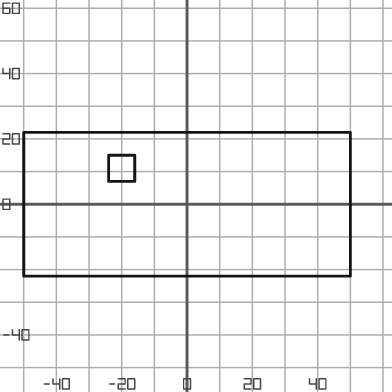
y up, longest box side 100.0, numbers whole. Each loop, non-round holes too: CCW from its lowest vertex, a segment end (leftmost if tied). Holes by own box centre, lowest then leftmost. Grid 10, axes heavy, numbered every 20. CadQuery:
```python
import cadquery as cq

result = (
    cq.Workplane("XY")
    .moveTo(-50.0, -22.0)
    .lineTo(50.0, -22.0)
    .lineTo(50.0, 22.0)
    .lineTo(-50.0, 22.0)
    .close()
    .moveTo(-24.0, 7.0)
    .lineTo(-16.0, 7.0)
    .lineTo(-16.0, 15.0)
    .lineTo(-24.0, 15.0)
    .close()
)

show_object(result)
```